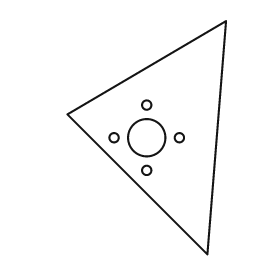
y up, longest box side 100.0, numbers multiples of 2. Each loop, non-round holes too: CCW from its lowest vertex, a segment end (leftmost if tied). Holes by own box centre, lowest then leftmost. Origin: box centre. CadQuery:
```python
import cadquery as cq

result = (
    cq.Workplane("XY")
    .moveTo(26.0, -50.0)
    .lineTo(34.0, 50.0)
    .lineTo(-34.0, 10.0)
    .close()
    .moveTo(0.0, -14.0)
    .circle(2.0)
    .moveTo(-14.0, 0.0)
    .circle(2.0)
    .moveTo(0.0, 0.0)
    .circle(8.0)
    .moveTo(14.0, 0.0)
    .circle(2.0)
    .moveTo(0.0, 14.0)
    .circle(2.0)
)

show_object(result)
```